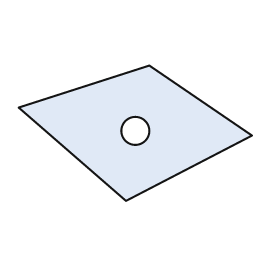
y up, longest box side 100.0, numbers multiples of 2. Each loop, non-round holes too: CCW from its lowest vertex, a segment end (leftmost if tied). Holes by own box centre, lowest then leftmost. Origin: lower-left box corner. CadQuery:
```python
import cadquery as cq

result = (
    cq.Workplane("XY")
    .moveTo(46.0, 0.0)
    .lineTo(100.0, 28.0)
    .lineTo(56.0, 58.0)
    .lineTo(0.0, 40.0)
    .close()
    .moveTo(50.0, 30.0)
    .circle(6.0)
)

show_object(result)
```